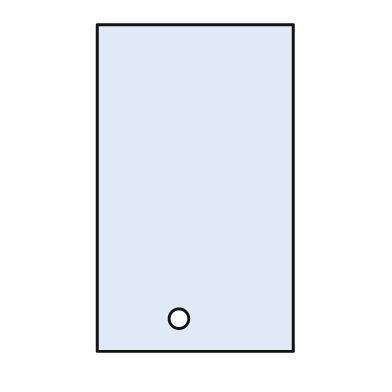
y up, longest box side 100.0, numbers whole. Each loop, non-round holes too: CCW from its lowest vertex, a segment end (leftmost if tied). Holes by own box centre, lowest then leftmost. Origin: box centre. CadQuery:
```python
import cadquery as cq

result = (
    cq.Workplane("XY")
    .moveTo(-30.0, -50.0)
    .lineTo(30.0, -50.0)
    .lineTo(30.0, 50.0)
    .lineTo(-30.0, 50.0)
    .close()
    .moveTo(-5.0, -40.0)
    .circle(3.0)
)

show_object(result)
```